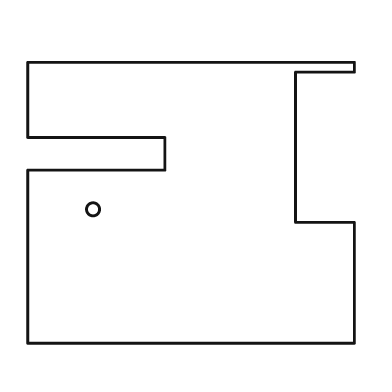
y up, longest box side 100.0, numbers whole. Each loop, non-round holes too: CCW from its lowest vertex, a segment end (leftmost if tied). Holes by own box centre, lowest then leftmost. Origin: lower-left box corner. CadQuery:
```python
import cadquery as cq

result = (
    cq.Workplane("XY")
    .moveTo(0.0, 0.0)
    .lineTo(100.0, 0.0)
    .lineTo(100.0, 37.0)
    .lineTo(82.0, 37.0)
    .lineTo(82.0, 83.0)
    .lineTo(100.0, 83.0)
    .lineTo(100.0, 86.0)
    .lineTo(0.0, 86.0)
    .lineTo(0.0, 63.0)
    .lineTo(42.0, 63.0)
    .lineTo(42.0, 53.0)
    .lineTo(0.0, 53.0)
    .close()
    .moveTo(20.0, 41.0)
    .circle(2.0)
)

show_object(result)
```